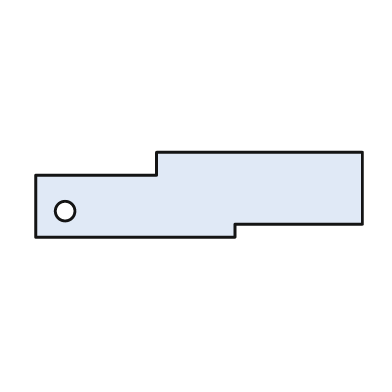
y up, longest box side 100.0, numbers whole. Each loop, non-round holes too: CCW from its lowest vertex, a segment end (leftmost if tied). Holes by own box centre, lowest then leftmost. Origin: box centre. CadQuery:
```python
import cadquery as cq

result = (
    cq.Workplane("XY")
    .moveTo(-50.0, -13.0)
    .lineTo(11.0, -13.0)
    .lineTo(11.0, -9.0)
    .lineTo(50.0, -9.0)
    .lineTo(50.0, 13.0)
    .lineTo(-13.0, 13.0)
    .lineTo(-13.0, 6.0)
    .lineTo(-50.0, 6.0)
    .close()
    .moveTo(-41.0, -5.0)
    .circle(3.0)
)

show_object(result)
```